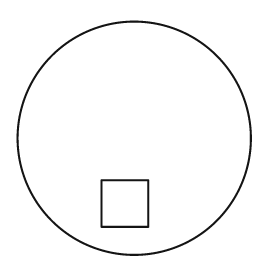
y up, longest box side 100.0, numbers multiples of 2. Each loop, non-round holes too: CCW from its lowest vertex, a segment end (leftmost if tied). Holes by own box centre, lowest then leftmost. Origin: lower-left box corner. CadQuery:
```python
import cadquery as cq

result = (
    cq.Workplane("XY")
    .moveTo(50.0, 50.0)
    .circle(50.0)
    .moveTo(36.0, 12.0)
    .lineTo(56.0, 12.0)
    .lineTo(56.0, 32.0)
    .lineTo(36.0, 32.0)
    .close()
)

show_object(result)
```